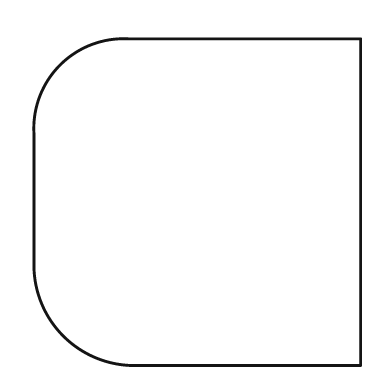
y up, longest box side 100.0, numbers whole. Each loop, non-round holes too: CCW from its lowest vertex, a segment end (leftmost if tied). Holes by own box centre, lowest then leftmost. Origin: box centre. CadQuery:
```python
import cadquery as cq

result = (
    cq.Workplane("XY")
    .moveTo(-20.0, -50.0)
    .lineTo(50.0, -50.0)
    .lineTo(50.0, 50.0)
    .lineTo(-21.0, 50.0)
    .threePointArc((-42.0, 42.0), (-50.0, 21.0))
    .lineTo(-50.0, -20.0)
    .threePointArc((-41.0, -41.0), (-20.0, -50.0))
    .close()
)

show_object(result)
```